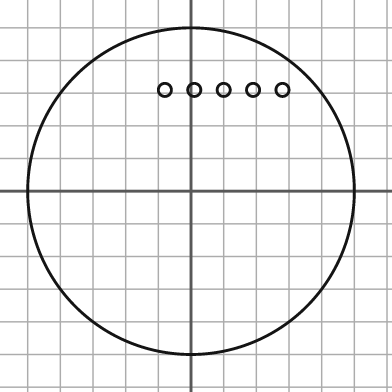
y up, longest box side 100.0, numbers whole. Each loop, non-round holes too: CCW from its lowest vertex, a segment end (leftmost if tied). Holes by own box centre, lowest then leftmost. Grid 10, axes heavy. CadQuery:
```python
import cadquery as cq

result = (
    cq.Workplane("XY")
    .moveTo(0.0, 0.0)
    .circle(50.0)
    .moveTo(-8.0, 31.0)
    .circle(2.0)
    .moveTo(1.0, 31.0)
    .circle(2.0)
    .moveTo(10.0, 31.0)
    .circle(2.0)
    .moveTo(19.0, 31.0)
    .circle(2.0)
    .moveTo(28.0, 31.0)
    .circle(2.0)
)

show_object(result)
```